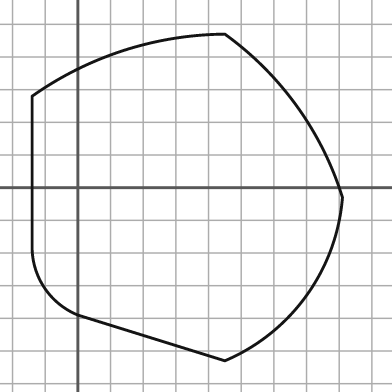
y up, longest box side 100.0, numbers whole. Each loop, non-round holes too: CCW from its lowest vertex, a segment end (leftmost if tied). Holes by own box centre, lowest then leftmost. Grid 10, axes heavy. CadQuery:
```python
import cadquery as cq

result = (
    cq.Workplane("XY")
    .moveTo(45.0, -53.0)
    .threePointArc((70.0, -33.0), (81.0, -3.0))
    .threePointArc((67.0, 25.0), (45.0, 47.0))
    .threePointArc((14.0, 42.0), (-14.0, 28.0))
    .lineTo(-14.0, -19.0)
    .threePointArc((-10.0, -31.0), (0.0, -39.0))
    .close()
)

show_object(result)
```